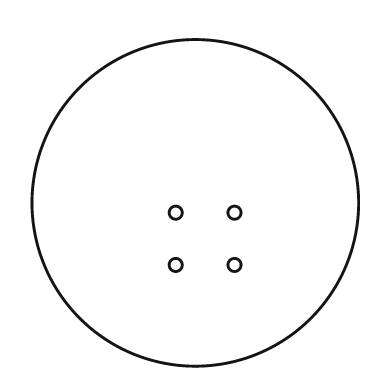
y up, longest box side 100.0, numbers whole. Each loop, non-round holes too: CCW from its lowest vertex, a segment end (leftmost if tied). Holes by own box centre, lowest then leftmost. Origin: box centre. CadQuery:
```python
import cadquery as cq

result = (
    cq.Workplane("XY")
    .moveTo(0.0, 0.0)
    .circle(50.0)
    .moveTo(-6.0, -19.0)
    .circle(2.0)
    .moveTo(12.0, -19.0)
    .circle(2.0)
    .moveTo(-6.0, -3.0)
    .circle(2.0)
    .moveTo(12.0, -3.0)
    .circle(2.0)
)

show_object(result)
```